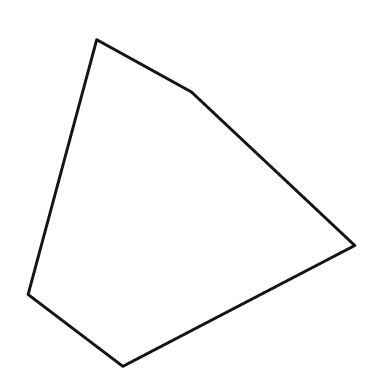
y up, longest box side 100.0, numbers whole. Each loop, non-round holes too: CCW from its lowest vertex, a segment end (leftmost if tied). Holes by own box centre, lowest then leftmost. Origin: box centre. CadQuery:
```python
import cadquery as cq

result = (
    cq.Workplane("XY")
    .moveTo(-21.0, -50.0)
    .lineTo(50.0, -13.0)
    .lineTo(0.0, 34.0)
    .lineTo(-29.0, 50.0)
    .lineTo(-50.0, -28.0)
    .close()
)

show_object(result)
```